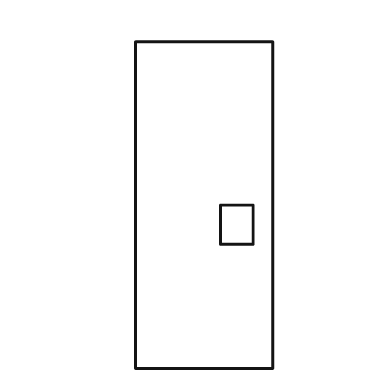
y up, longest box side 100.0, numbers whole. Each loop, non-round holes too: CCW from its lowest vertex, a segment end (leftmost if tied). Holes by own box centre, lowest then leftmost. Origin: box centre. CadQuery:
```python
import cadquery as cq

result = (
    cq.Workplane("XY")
    .moveTo(-21.0, -50.0)
    .lineTo(21.0, -50.0)
    .lineTo(21.0, 50.0)
    .lineTo(-21.0, 50.0)
    .close()
    .moveTo(5.0, -12.0)
    .lineTo(15.0, -12.0)
    .lineTo(15.0, 0.0)
    .lineTo(5.0, 0.0)
    .close()
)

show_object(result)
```